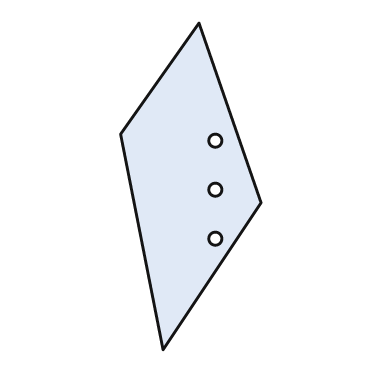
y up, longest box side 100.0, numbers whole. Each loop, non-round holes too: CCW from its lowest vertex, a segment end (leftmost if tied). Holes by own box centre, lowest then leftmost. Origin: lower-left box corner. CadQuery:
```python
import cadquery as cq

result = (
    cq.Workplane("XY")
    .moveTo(13.0, 0.0)
    .lineTo(43.0, 45.0)
    .lineTo(24.0, 100.0)
    .lineTo(0.0, 66.0)
    .close()
    .moveTo(29.0, 34.0)
    .circle(2.0)
    .moveTo(29.0, 49.0)
    .circle(2.0)
    .moveTo(29.0, 64.0)
    .circle(2.0)
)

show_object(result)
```